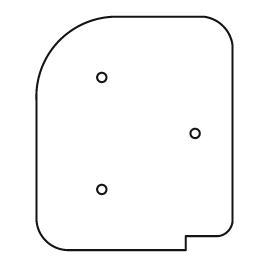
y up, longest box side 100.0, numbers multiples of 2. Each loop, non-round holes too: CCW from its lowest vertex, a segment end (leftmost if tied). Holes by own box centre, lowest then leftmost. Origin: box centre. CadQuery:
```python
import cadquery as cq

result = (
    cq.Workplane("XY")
    .moveTo(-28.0, -50.0)
    .lineTo(22.0, -50.0)
    .lineTo(22.0, -44.0)
    .lineTo(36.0, -44.0)
    .threePointArc((40.0, -42.0), (42.0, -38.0))
    .lineTo(42.0, 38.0)
    .threePointArc((38.0, 46.0), (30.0, 50.0))
    .lineTo(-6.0, 50.0)
    .threePointArc((-32.0, 40.0), (-42.0, 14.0))
    .lineTo(-42.0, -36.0)
    .threePointArc((-38.0, -46.0), (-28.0, -50.0))
    .close()
    .moveTo(-14.0, -24.0)
    .circle(2.0)
    .moveTo(26.0, 0.0)
    .circle(2.0)
    .moveTo(-14.0, 24.0)
    .circle(2.0)
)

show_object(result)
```